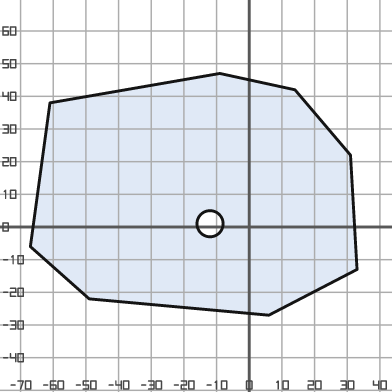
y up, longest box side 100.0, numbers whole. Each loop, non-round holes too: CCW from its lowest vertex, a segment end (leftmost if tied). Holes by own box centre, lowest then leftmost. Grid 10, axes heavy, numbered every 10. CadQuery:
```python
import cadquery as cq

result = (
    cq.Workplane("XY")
    .moveTo(6.0, -27.0)
    .lineTo(33.0, -13.0)
    .lineTo(31.0, 22.0)
    .lineTo(14.0, 42.0)
    .lineTo(-9.0, 47.0)
    .lineTo(-61.0, 38.0)
    .lineTo(-67.0, -6.0)
    .lineTo(-49.0, -22.0)
    .close()
    .moveTo(-12.0, 1.0)
    .circle(4.0)
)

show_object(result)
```